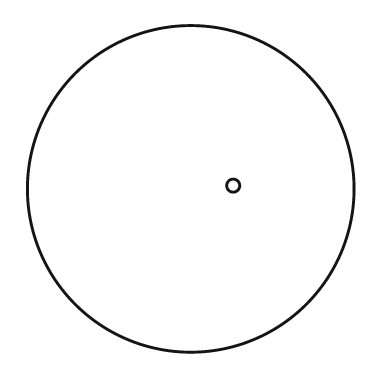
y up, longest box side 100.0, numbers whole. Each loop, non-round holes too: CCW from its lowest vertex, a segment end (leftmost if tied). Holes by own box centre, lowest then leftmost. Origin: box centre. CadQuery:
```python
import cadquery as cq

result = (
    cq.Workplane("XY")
    .moveTo(0.0, 0.0)
    .circle(50.0)
    .moveTo(13.0, 1.0)
    .circle(2.0)
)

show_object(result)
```